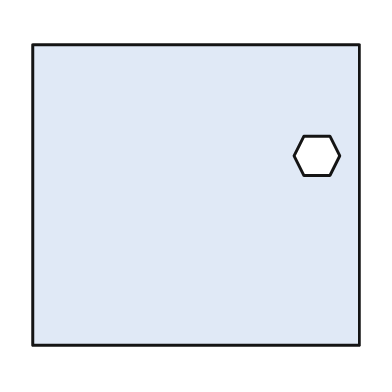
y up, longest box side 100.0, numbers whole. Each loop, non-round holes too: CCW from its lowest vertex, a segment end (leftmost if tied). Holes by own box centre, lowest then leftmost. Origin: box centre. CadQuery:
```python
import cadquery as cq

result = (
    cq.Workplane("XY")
    .moveTo(-50.0, -46.0)
    .lineTo(50.0, -46.0)
    .lineTo(50.0, 46.0)
    .lineTo(-50.0, 46.0)
    .close()
    .moveTo(33.0, 6.0)
    .lineTo(41.0, 6.0)
    .lineTo(44.0, 12.0)
    .lineTo(41.0, 18.0)
    .lineTo(33.0, 18.0)
    .lineTo(30.0, 12.0)
    .close()
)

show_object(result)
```